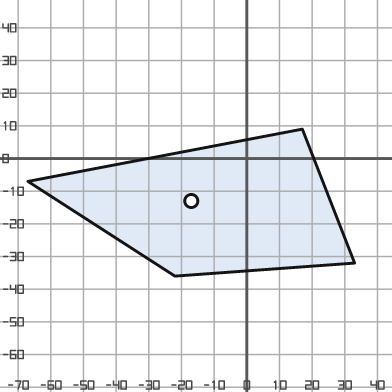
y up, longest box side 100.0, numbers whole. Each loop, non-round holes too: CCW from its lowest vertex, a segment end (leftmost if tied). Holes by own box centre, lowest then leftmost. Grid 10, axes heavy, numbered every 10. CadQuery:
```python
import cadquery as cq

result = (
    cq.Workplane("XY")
    .moveTo(-22.0, -36.0)
    .lineTo(33.0, -32.0)
    .lineTo(17.0, 9.0)
    .lineTo(-67.0, -7.0)
    .close()
    .moveTo(-17.0, -13.0)
    .circle(2.0)
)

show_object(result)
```